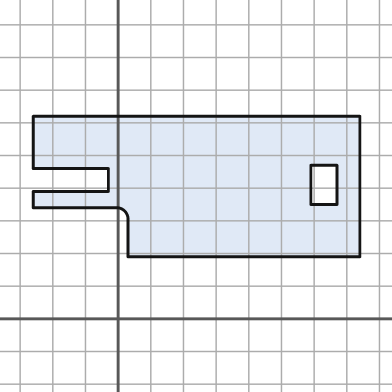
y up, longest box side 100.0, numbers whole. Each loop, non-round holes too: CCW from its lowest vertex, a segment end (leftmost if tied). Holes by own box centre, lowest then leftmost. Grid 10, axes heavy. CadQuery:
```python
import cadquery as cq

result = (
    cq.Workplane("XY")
    .moveTo(3.0, 19.0)
    .lineTo(74.0, 19.0)
    .lineTo(74.0, 62.0)
    .lineTo(-26.0, 62.0)
    .lineTo(-26.0, 46.0)
    .lineTo(-3.0, 46.0)
    .lineTo(-3.0, 39.0)
    .lineTo(-26.0, 39.0)
    .lineTo(-26.0, 34.0)
    .lineTo(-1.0, 34.0)
    .threePointArc((2.0, 33.0), (3.0, 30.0))
    .close()
    .moveTo(59.0, 35.0)
    .lineTo(67.0, 35.0)
    .lineTo(67.0, 47.0)
    .lineTo(59.0, 47.0)
    .close()
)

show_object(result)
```